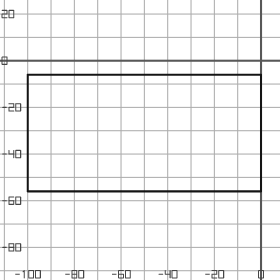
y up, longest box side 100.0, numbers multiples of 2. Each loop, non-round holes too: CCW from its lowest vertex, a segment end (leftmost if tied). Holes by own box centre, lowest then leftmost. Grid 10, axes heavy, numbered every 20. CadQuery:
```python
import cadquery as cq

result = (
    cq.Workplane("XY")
    .moveTo(-100.0, -56.0)
    .lineTo(0.0, -56.0)
    .lineTo(0.0, -6.0)
    .lineTo(-100.0, -6.0)
    .close()
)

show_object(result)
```